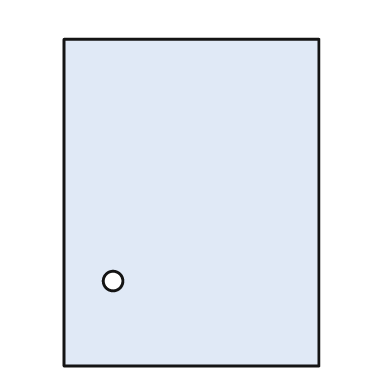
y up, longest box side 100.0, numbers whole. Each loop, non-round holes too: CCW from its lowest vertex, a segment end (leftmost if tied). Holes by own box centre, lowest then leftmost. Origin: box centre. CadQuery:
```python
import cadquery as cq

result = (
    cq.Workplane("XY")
    .moveTo(-39.0, -50.0)
    .lineTo(39.0, -50.0)
    .lineTo(39.0, 50.0)
    .lineTo(-39.0, 50.0)
    .close()
    .moveTo(-24.0, -24.0)
    .circle(3.0)
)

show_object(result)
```